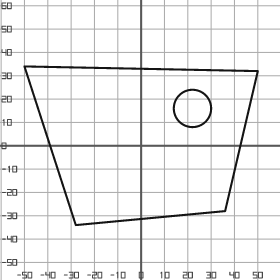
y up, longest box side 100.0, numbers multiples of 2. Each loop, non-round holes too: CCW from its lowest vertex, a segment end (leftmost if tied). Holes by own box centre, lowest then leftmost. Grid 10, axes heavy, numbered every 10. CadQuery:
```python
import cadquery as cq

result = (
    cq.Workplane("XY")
    .moveTo(-28.0, -34.0)
    .lineTo(36.0, -28.0)
    .lineTo(50.0, 32.0)
    .lineTo(-50.0, 34.0)
    .close()
    .moveTo(22.0, 16.0)
    .circle(8.0)
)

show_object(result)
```